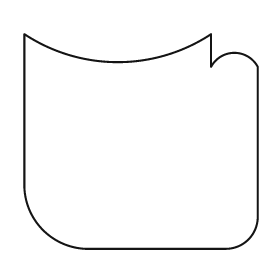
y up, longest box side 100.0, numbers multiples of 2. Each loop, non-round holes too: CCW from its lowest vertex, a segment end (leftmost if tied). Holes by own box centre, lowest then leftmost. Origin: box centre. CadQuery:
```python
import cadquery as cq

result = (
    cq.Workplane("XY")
    .moveTo(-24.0, -46.0)
    .lineTo(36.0, -46.0)
    .threePointArc((46.0, -42.0), (50.0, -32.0))
    .lineTo(50.0, 32.0)
    .threePointArc((40.0, 38.0), (30.0, 32.0))
    .lineTo(30.0, 46.0)
    .threePointArc((-10.0, 34.0), (-50.0, 46.0))
    .lineTo(-50.0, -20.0)
    .threePointArc((-42.0, -38.0), (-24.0, -46.0))
    .close()
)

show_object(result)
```